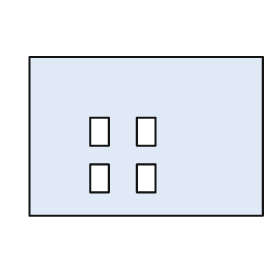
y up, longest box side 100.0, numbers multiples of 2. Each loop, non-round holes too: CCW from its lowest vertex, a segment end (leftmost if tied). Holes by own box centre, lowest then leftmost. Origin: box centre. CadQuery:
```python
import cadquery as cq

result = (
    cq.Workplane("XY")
    .moveTo(-50.0, -34.0)
    .lineTo(50.0, -34.0)
    .lineTo(50.0, 34.0)
    .lineTo(-50.0, 34.0)
    .close()
    .moveTo(-24.0, -24.0)
    .lineTo(-16.0, -24.0)
    .lineTo(-16.0, -12.0)
    .lineTo(-24.0, -12.0)
    .close()
    .moveTo(-4.0, -24.0)
    .lineTo(4.0, -24.0)
    .lineTo(4.0, -12.0)
    .lineTo(-4.0, -12.0)
    .close()
    .moveTo(-24.0, -4.0)
    .lineTo(-16.0, -4.0)
    .lineTo(-16.0, 8.0)
    .lineTo(-24.0, 8.0)
    .close()
    .moveTo(-4.0, -4.0)
    .lineTo(4.0, -4.0)
    .lineTo(4.0, 8.0)
    .lineTo(-4.0, 8.0)
    .close()
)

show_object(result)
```